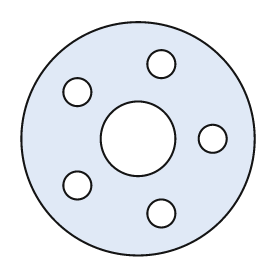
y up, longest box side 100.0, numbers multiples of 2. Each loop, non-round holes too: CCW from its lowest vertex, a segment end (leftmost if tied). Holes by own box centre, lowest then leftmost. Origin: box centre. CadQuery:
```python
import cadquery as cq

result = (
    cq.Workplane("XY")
    .moveTo(0.0, 0.0)
    .circle(50.0)
    .moveTo(10.0, -32.0)
    .circle(6.0)
    .moveTo(-26.0, -20.0)
    .circle(6.0)
    .moveTo(0.0, 0.0)
    .circle(16.0)
    .moveTo(32.0, 0.0)
    .circle(6.0)
    .moveTo(-26.0, 20.0)
    .circle(6.0)
    .moveTo(10.0, 32.0)
    .circle(6.0)
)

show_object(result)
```